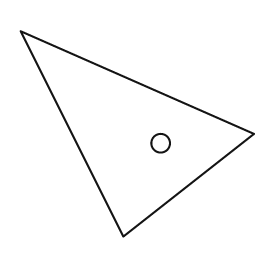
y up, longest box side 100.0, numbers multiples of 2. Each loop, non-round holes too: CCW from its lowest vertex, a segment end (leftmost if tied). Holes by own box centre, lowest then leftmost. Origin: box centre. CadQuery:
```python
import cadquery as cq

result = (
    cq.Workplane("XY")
    .moveTo(-6.0, -44.0)
    .lineTo(50.0, 0.0)
    .lineTo(-50.0, 44.0)
    .close()
    .moveTo(10.0, -4.0)
    .circle(4.0)
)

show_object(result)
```